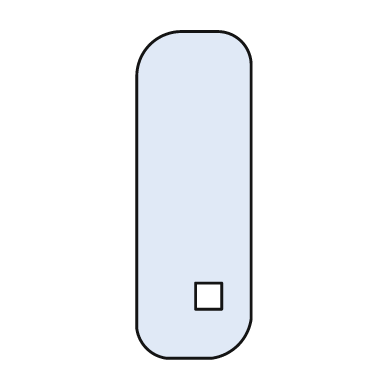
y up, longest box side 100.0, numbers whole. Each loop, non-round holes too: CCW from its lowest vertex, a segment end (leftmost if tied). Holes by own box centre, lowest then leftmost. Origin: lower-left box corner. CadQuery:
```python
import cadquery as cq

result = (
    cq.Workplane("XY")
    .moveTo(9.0, 0.0)
    .lineTo(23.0, 0.0)
    .threePointArc((31.0, 4.0), (35.0, 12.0))
    .lineTo(35.0, 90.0)
    .threePointArc((32.0, 97.0), (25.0, 100.0))
    .lineTo(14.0, 100.0)
    .threePointArc((4.0, 96.0), (0.0, 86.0))
    .lineTo(0.0, 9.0)
    .threePointArc((3.0, 3.0), (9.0, 0.0))
    .close()
    .moveTo(18.0, 15.0)
    .lineTo(26.0, 15.0)
    .lineTo(26.0, 23.0)
    .lineTo(18.0, 23.0)
    .close()
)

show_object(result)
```